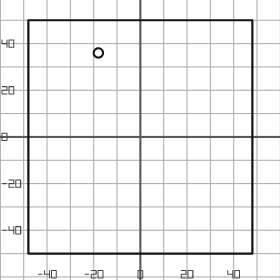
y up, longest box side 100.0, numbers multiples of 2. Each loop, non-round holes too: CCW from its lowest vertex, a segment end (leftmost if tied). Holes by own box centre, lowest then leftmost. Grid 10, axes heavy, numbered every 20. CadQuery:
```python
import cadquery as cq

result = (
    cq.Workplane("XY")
    .moveTo(-48.0, -50.0)
    .lineTo(48.0, -50.0)
    .lineTo(48.0, 50.0)
    .lineTo(-48.0, 50.0)
    .close()
    .moveTo(-18.0, 36.0)
    .circle(2.0)
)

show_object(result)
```